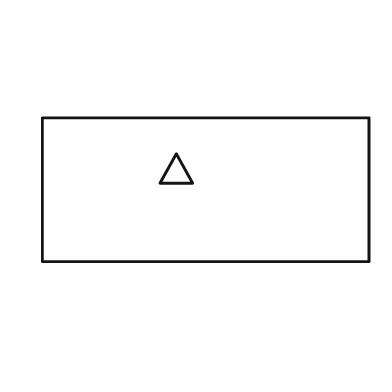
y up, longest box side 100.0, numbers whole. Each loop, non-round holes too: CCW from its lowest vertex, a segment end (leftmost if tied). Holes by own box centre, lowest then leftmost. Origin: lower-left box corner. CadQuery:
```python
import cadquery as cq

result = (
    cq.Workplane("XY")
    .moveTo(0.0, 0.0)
    .lineTo(100.0, 0.0)
    .lineTo(100.0, 44.0)
    .lineTo(0.0, 44.0)
    .close()
    .moveTo(36.0, 24.0)
    .lineTo(46.0, 24.0)
    .lineTo(41.0, 33.0)
    .close()
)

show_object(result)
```